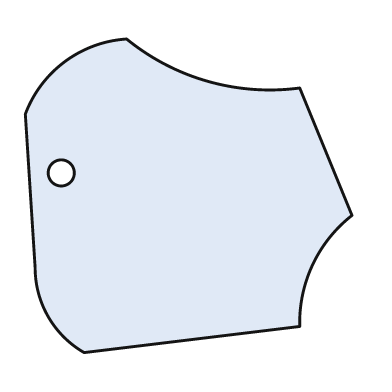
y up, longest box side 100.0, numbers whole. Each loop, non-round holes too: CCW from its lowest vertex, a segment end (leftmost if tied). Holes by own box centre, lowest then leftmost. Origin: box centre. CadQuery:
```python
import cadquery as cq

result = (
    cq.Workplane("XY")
    .moveTo(-32.0, -48.0)
    .lineTo(34.0, -40.0)
    .threePointArc((38.0, -21.0), (50.0, -6.0))
    .lineTo(34.0, 33.0)
    .threePointArc((6.0, 35.0), (-19.0, 48.0))
    .threePointArc((-38.0, 41.0), (-50.0, 25.0))
    .lineTo(-47.0, -22.0)
    .threePointArc((-43.0, -37.0), (-32.0, -48.0))
    .close()
    .moveTo(-39.0, 7.0)
    .circle(4.0)
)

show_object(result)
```